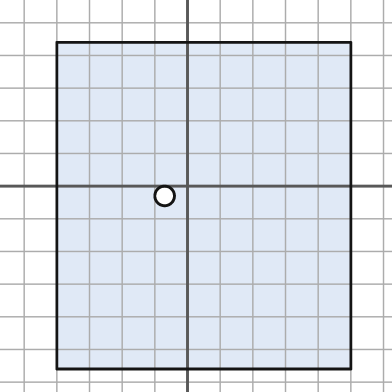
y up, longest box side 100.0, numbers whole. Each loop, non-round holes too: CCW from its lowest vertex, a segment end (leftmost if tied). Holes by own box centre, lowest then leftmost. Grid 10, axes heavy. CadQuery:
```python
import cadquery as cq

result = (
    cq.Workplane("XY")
    .moveTo(-40.0, -56.0)
    .lineTo(50.0, -56.0)
    .lineTo(50.0, 44.0)
    .lineTo(-40.0, 44.0)
    .close()
    .moveTo(-7.0, -3.0)
    .circle(3.0)
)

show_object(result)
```